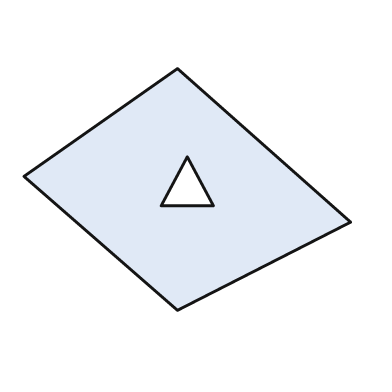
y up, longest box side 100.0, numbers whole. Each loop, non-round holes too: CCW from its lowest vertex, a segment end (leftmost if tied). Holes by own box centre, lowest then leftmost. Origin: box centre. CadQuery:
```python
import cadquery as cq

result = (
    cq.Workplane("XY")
    .moveTo(-3.0, -37.0)
    .lineTo(50.0, -10.0)
    .lineTo(-3.0, 37.0)
    .lineTo(-50.0, 4.0)
    .close()
    .moveTo(-8.0, -5.0)
    .lineTo(8.0, -5.0)
    .lineTo(0.0, 10.0)
    .close()
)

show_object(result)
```